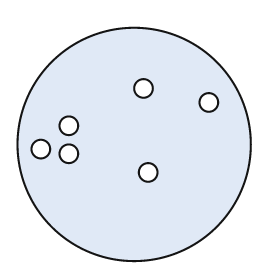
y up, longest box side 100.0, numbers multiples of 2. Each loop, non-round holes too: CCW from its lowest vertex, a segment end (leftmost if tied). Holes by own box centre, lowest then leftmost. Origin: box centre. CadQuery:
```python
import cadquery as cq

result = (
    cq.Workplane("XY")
    .moveTo(0.0, 0.0)
    .circle(50.0)
    .moveTo(6.0, -12.0)
    .circle(4.0)
    .moveTo(-28.0, -4.0)
    .circle(4.0)
    .moveTo(-40.0, -2.0)
    .circle(4.0)
    .moveTo(-28.0, 8.0)
    .circle(4.0)
    .moveTo(32.0, 18.0)
    .circle(4.0)
    .moveTo(4.0, 24.0)
    .circle(4.0)
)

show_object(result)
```